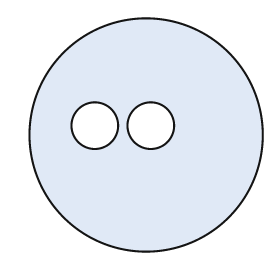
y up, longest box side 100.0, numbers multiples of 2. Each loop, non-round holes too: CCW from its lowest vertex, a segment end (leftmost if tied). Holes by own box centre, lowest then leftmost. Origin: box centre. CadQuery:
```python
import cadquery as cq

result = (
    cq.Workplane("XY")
    .moveTo(0.0, 0.0)
    .circle(50.0)
    .moveTo(-22.0, 4.0)
    .circle(10.0)
    .moveTo(2.0, 4.0)
    .circle(10.0)
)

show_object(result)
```